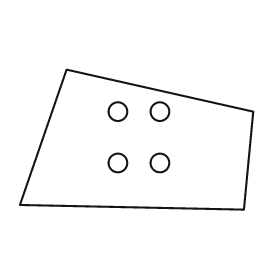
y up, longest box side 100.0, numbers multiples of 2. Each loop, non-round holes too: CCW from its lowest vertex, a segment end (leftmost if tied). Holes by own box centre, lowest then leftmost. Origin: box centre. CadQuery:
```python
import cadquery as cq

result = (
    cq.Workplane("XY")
    .moveTo(46.0, -30.0)
    .lineTo(50.0, 12.0)
    .lineTo(-30.0, 30.0)
    .lineTo(-50.0, -28.0)
    .close()
    .moveTo(-8.0, -10.0)
    .circle(4.0)
    .moveTo(10.0, -10.0)
    .circle(4.0)
    .moveTo(-8.0, 12.0)
    .circle(4.0)
    .moveTo(10.0, 12.0)
    .circle(4.0)
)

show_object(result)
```